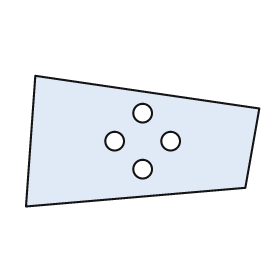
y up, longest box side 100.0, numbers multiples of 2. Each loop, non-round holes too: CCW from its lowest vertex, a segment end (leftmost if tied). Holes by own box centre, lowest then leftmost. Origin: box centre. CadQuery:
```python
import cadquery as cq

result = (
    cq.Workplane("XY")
    .moveTo(-50.0, -28.0)
    .lineTo(44.0, -20.0)
    .lineTo(50.0, 14.0)
    .lineTo(-46.0, 28.0)
    .close()
    .moveTo(0.0, -12.0)
    .circle(4.0)
    .moveTo(-12.0, 0.0)
    .circle(4.0)
    .moveTo(12.0, 0.0)
    .circle(4.0)
    .moveTo(0.0, 12.0)
    .circle(4.0)
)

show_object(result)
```